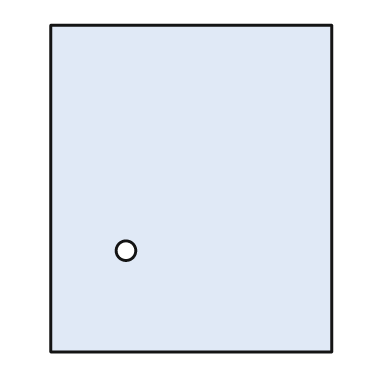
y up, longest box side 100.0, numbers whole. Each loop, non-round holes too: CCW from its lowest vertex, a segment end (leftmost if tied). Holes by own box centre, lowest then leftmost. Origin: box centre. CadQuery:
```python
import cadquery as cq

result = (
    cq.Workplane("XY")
    .moveTo(-43.0, -50.0)
    .lineTo(43.0, -50.0)
    .lineTo(43.0, 50.0)
    .lineTo(-43.0, 50.0)
    .close()
    .moveTo(-20.0, -19.0)
    .circle(3.0)
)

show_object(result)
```